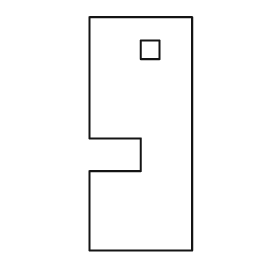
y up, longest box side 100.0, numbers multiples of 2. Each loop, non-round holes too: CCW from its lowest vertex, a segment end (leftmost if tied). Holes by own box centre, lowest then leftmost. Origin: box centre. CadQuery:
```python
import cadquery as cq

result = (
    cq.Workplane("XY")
    .moveTo(-22.0, -50.0)
    .lineTo(22.0, -50.0)
    .lineTo(22.0, 50.0)
    .lineTo(-22.0, 50.0)
    .lineTo(-22.0, -2.0)
    .lineTo(0.0, -2.0)
    .lineTo(0.0, -16.0)
    .lineTo(-22.0, -16.0)
    .close()
    .moveTo(0.0, 32.0)
    .lineTo(8.0, 32.0)
    .lineTo(8.0, 40.0)
    .lineTo(0.0, 40.0)
    .close()
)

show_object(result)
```